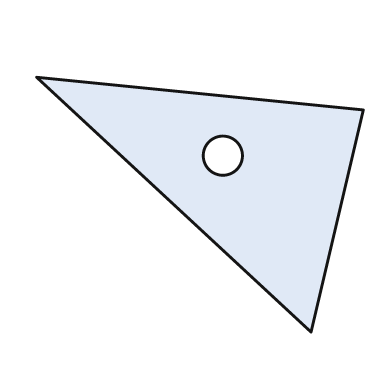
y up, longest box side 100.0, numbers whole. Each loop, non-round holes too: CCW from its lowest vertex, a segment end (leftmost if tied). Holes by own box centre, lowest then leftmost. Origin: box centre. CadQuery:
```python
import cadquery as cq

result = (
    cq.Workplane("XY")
    .moveTo(34.0, -39.0)
    .lineTo(50.0, 29.0)
    .lineTo(-50.0, 39.0)
    .close()
    .moveTo(7.0, 15.0)
    .circle(6.0)
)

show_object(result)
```